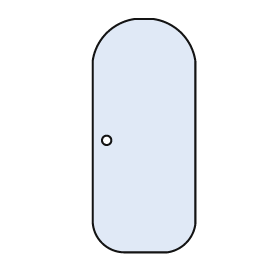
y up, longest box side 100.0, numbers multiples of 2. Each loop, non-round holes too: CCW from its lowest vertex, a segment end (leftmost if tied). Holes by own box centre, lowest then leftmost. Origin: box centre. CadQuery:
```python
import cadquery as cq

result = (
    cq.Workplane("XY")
    .moveTo(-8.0, -50.0)
    .lineTo(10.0, -50.0)
    .threePointArc((18.0, -46.0), (22.0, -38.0))
    .lineTo(22.0, 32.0)
    .threePointArc((16.0, 44.0), (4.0, 50.0))
    .lineTo(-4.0, 50.0)
    .threePointArc((-16.0, 44.0), (-22.0, 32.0))
    .lineTo(-22.0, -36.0)
    .threePointArc((-18.0, -46.0), (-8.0, -50.0))
    .close()
    .moveTo(-16.0, -2.0)
    .circle(2.0)
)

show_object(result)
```